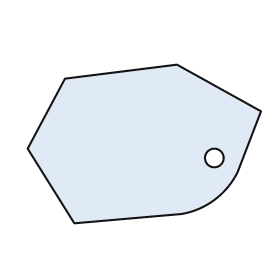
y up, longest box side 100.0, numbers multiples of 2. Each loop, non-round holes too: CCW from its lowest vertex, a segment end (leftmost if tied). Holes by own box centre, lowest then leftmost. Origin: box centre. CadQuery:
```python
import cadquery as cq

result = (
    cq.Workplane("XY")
    .moveTo(-30.0, -34.0)
    .lineTo(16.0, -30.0)
    .threePointArc((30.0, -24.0), (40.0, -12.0))
    .lineTo(50.0, 14.0)
    .lineTo(14.0, 34.0)
    .lineTo(-34.0, 28.0)
    .lineTo(-50.0, -2.0)
    .close()
    .moveTo(30.0, -6.0)
    .circle(4.0)
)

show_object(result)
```